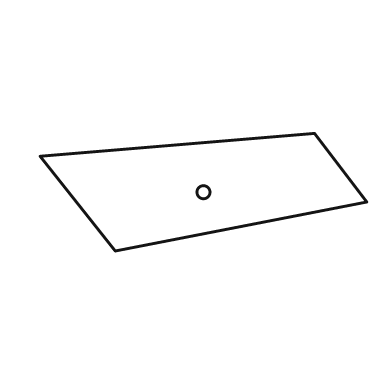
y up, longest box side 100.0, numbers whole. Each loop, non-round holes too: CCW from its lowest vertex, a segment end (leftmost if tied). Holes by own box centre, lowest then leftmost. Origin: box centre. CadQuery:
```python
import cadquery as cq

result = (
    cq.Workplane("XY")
    .moveTo(-27.0, -18.0)
    .lineTo(50.0, -3.0)
    .lineTo(34.0, 18.0)
    .lineTo(-50.0, 11.0)
    .close()
    .moveTo(0.0, 0.0)
    .circle(2.0)
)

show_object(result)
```